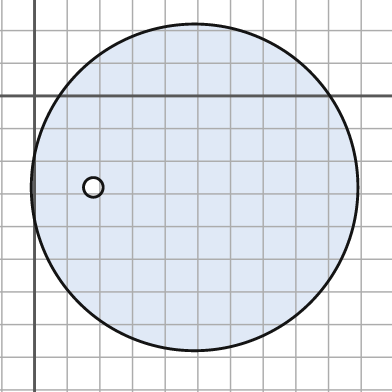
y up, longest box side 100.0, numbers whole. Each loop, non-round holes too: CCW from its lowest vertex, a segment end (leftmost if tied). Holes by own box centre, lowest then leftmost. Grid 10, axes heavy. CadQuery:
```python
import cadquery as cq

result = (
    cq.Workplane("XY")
    .moveTo(49.0, -28.0)
    .circle(50.0)
    .moveTo(18.0, -28.0)
    .circle(3.0)
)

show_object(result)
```